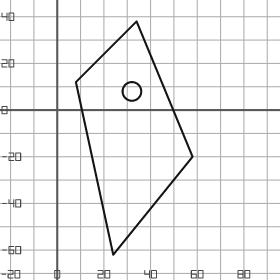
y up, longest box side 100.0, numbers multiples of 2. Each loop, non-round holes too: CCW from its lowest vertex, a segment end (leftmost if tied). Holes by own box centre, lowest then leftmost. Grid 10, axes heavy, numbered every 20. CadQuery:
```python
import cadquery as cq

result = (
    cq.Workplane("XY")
    .moveTo(24.0, -62.0)
    .lineTo(58.0, -20.0)
    .lineTo(34.0, 38.0)
    .lineTo(8.0, 12.0)
    .close()
    .moveTo(32.0, 8.0)
    .circle(4.0)
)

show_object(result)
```